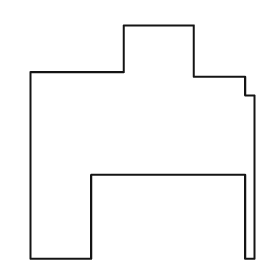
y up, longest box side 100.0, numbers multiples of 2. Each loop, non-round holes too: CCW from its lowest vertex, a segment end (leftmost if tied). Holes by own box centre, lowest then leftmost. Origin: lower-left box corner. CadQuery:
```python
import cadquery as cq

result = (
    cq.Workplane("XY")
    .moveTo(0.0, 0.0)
    .lineTo(26.0, 0.0)
    .lineTo(26.0, 36.0)
    .lineTo(92.0, 36.0)
    .lineTo(92.0, 0.0)
    .lineTo(96.0, 0.0)
    .lineTo(96.0, 70.0)
    .lineTo(92.0, 70.0)
    .lineTo(92.0, 78.0)
    .lineTo(70.0, 78.0)
    .lineTo(70.0, 100.0)
    .lineTo(40.0, 100.0)
    .lineTo(40.0, 80.0)
    .lineTo(0.0, 80.0)
    .close()
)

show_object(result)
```